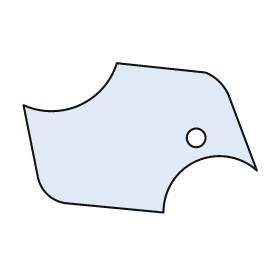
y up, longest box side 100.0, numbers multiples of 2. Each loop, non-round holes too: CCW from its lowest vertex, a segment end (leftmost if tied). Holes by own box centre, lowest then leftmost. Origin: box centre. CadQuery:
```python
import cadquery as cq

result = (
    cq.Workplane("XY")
    .moveTo(10.0, -32.0)
    .threePointArc((24.0, -10.0), (50.0, -14.0))
    .lineTo(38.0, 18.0)
    .threePointArc((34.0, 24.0), (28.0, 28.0))
    .lineTo(-10.0, 32.0)
    .threePointArc((-26.0, 14.0), (-50.0, 14.0))
    .lineTo(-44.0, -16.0)
    .threePointArc((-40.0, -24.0), (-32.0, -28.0))
    .close()
    .moveTo(24.0, 0.0)
    .circle(4.0)
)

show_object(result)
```